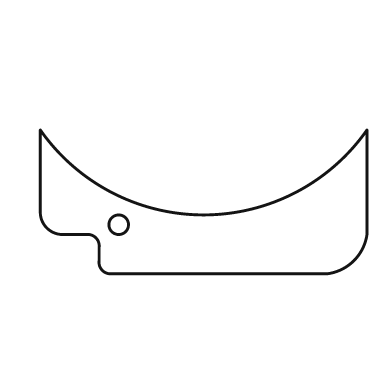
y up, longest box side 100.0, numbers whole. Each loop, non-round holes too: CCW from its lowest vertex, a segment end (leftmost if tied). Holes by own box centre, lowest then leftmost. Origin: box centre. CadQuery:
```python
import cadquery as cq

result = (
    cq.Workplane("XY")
    .moveTo(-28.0, -22.0)
    .lineTo(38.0, -22.0)
    .threePointArc((46.0, -18.0), (50.0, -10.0))
    .lineTo(50.0, 22.0)
    .threePointArc((0.0, -4.0), (-50.0, 22.0))
    .lineTo(-50.0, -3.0)
    .threePointArc((-48.0, -8.0), (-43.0, -10.0))
    .lineTo(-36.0, -10.0)
    .threePointArc((-33.0, -11.0), (-32.0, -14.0))
    .lineTo(-32.0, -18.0)
    .threePointArc((-31.0, -21.0), (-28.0, -22.0))
    .close()
    .moveTo(-26.0, -7.0)
    .circle(3.0)
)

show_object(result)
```